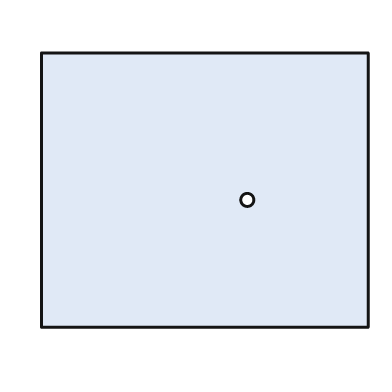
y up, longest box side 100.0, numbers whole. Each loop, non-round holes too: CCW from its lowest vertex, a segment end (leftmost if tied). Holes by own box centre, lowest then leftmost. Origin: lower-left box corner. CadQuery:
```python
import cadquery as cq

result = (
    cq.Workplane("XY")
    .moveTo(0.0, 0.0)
    .lineTo(100.0, 0.0)
    .lineTo(100.0, 84.0)
    .lineTo(0.0, 84.0)
    .close()
    .moveTo(63.0, 39.0)
    .circle(2.0)
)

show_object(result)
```